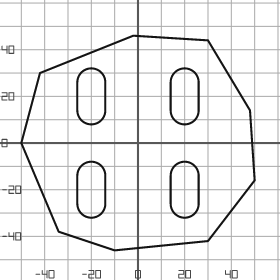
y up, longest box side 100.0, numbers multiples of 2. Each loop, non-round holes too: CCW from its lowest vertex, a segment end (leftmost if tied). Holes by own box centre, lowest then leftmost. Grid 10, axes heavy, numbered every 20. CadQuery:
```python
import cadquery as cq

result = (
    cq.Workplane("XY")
    .moveTo(-10.0, -46.0)
    .lineTo(30.0, -42.0)
    .lineTo(50.0, -16.0)
    .lineTo(48.0, 14.0)
    .lineTo(30.0, 44.0)
    .lineTo(-2.0, 46.0)
    .lineTo(-42.0, 30.0)
    .lineTo(-50.0, 0.0)
    .lineTo(-34.0, -38.0)
    .close()
    .moveTo(-26.0, -26.0)
    .threePointArc((-20.0, -32.0), (-14.0, -26.0))
    .lineTo(-14.0, -14.0)
    .threePointArc((-20.0, -8.0), (-26.0, -14.0))
    .close()
    .moveTo(14.0, -26.0)
    .threePointArc((20.0, -32.0), (26.0, -26.0))
    .lineTo(26.0, -14.0)
    .threePointArc((20.0, -8.0), (14.0, -14.0))
    .close()
    .moveTo(-26.0, 14.0)
    .threePointArc((-20.0, 8.0), (-14.0, 14.0))
    .lineTo(-14.0, 26.0)
    .threePointArc((-20.0, 32.0), (-26.0, 26.0))
    .close()
    .moveTo(14.0, 14.0)
    .threePointArc((20.0, 8.0), (26.0, 14.0))
    .lineTo(26.0, 26.0)
    .threePointArc((20.0, 32.0), (14.0, 26.0))
    .close()
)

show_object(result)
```